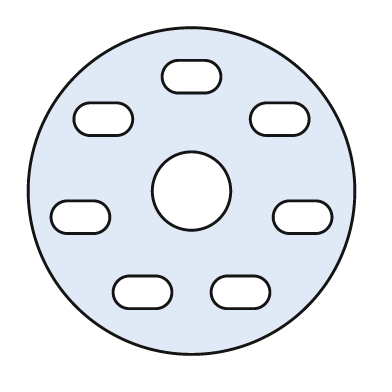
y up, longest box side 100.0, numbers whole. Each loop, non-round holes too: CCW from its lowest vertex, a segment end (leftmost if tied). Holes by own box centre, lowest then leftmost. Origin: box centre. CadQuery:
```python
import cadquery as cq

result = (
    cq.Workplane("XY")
    .moveTo(0.0, 0.0)
    .circle(50.0)
    .moveTo(-19.0, -36.0)
    .lineTo(-11.0, -36.0)
    .threePointArc((-6.0, -31.0), (-11.0, -26.0))
    .lineTo(-19.0, -26.0)
    .threePointArc((-24.0, -31.0), (-19.0, -36.0))
    .close()
    .moveTo(11.0, -36.0)
    .lineTo(19.0, -36.0)
    .threePointArc((24.0, -31.0), (19.0, -26.0))
    .lineTo(11.0, -26.0)
    .threePointArc((6.0, -31.0), (11.0, -36.0))
    .close()
    .moveTo(-38.0, -13.0)
    .lineTo(-30.0, -13.0)
    .threePointArc((-25.0, -8.0), (-30.0, -3.0))
    .lineTo(-38.0, -3.0)
    .threePointArc((-43.0, -8.0), (-38.0, -13.0))
    .close()
    .moveTo(30.0, -13.0)
    .lineTo(38.0, -13.0)
    .threePointArc((43.0, -8.0), (38.0, -3.0))
    .lineTo(30.0, -3.0)
    .threePointArc((25.0, -8.0), (30.0, -13.0))
    .close()
    .moveTo(0.0, 0.0)
    .circle(12.0)
    .moveTo(-31.0, 17.0)
    .lineTo(-23.0, 17.0)
    .threePointArc((-18.0, 22.0), (-23.0, 27.0))
    .lineTo(-31.0, 27.0)
    .threePointArc((-36.0, 22.0), (-31.0, 17.0))
    .close()
    .moveTo(23.0, 17.0)
    .lineTo(31.0, 17.0)
    .threePointArc((36.0, 22.0), (31.0, 27.0))
    .lineTo(23.0, 27.0)
    .threePointArc((18.0, 22.0), (23.0, 17.0))
    .close()
    .moveTo(-4.0, 30.0)
    .lineTo(4.0, 30.0)
    .threePointArc((9.0, 35.0), (4.0, 40.0))
    .lineTo(-4.0, 40.0)
    .threePointArc((-9.0, 35.0), (-4.0, 30.0))
    .close()
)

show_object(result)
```